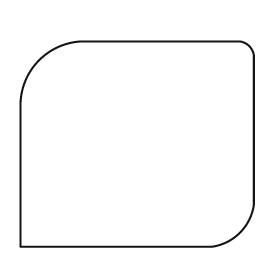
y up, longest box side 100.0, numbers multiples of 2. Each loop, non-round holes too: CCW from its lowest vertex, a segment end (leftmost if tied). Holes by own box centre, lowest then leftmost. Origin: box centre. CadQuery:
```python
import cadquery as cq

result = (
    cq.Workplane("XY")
    .moveTo(-50.0, -44.0)
    .lineTo(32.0, -44.0)
    .threePointArc((44.0, -38.0), (50.0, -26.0))
    .lineTo(50.0, 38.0)
    .threePointArc((48.0, 42.0), (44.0, 44.0))
    .lineTo(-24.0, 44.0)
    .threePointArc((-42.0, 36.0), (-50.0, 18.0))
    .close()
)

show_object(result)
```